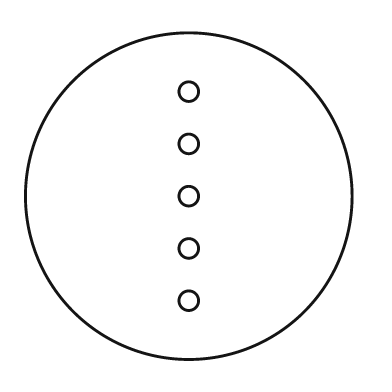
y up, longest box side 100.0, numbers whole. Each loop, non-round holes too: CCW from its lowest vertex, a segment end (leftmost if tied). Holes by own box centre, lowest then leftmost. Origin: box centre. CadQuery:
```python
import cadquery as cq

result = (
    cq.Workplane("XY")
    .moveTo(0.0, 0.0)
    .circle(50.0)
    .moveTo(0.0, -32.0)
    .circle(3.0)
    .moveTo(0.0, -16.0)
    .circle(3.0)
    .moveTo(0.0, 0.0)
    .circle(3.0)
    .moveTo(0.0, 16.0)
    .circle(3.0)
    .moveTo(0.0, 32.0)
    .circle(3.0)
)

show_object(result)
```